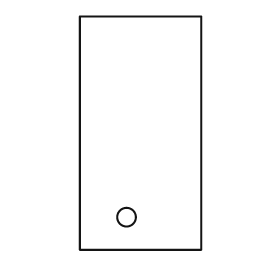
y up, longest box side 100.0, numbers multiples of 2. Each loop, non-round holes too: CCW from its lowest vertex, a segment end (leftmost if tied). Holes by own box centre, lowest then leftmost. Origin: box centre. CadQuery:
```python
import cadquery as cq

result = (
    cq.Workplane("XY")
    .moveTo(-26.0, -50.0)
    .lineTo(26.0, -50.0)
    .lineTo(26.0, 50.0)
    .lineTo(-26.0, 50.0)
    .close()
    .moveTo(-6.0, -36.0)
    .circle(4.0)
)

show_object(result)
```